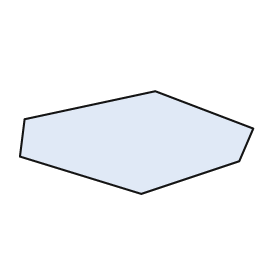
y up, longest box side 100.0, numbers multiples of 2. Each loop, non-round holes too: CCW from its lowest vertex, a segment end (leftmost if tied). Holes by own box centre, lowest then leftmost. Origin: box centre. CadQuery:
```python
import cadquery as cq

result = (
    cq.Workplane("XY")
    .moveTo(2.0, -22.0)
    .lineTo(44.0, -8.0)
    .lineTo(50.0, 6.0)
    .lineTo(8.0, 22.0)
    .lineTo(-48.0, 10.0)
    .lineTo(-50.0, -6.0)
    .close()
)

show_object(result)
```